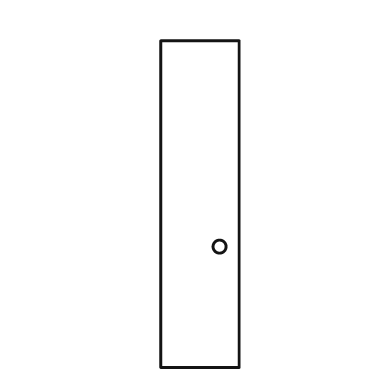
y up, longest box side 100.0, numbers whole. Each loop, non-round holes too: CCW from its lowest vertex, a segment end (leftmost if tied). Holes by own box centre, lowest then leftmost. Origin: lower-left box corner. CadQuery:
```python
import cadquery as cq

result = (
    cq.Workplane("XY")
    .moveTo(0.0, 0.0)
    .lineTo(24.0, 0.0)
    .lineTo(24.0, 100.0)
    .lineTo(0.0, 100.0)
    .close()
    .moveTo(18.0, 37.0)
    .circle(2.0)
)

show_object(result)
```